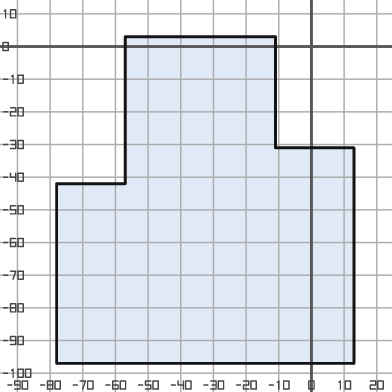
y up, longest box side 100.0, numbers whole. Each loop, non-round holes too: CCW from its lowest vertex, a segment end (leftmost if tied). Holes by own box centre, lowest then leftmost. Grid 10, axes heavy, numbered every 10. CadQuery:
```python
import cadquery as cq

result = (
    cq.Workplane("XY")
    .moveTo(-78.0, -97.0)
    .lineTo(13.0, -97.0)
    .lineTo(13.0, -31.0)
    .lineTo(-11.0, -31.0)
    .lineTo(-11.0, 3.0)
    .lineTo(-57.0, 3.0)
    .lineTo(-57.0, -42.0)
    .lineTo(-78.0, -42.0)
    .close()
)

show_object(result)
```